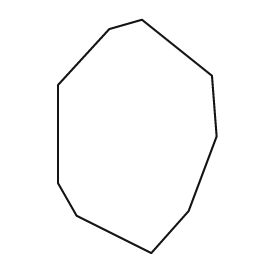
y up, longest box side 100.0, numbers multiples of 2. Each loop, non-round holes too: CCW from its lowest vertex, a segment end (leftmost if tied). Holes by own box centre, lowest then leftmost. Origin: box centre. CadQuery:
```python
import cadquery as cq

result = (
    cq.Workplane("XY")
    .moveTo(6.0, -50.0)
    .lineTo(22.0, -32.0)
    .lineTo(34.0, 0.0)
    .lineTo(32.0, 26.0)
    .lineTo(2.0, 50.0)
    .lineTo(-12.0, 46.0)
    .lineTo(-34.0, 22.0)
    .lineTo(-34.0, -20.0)
    .lineTo(-26.0, -34.0)
    .close()
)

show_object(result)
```